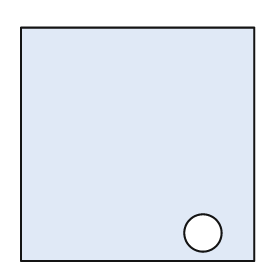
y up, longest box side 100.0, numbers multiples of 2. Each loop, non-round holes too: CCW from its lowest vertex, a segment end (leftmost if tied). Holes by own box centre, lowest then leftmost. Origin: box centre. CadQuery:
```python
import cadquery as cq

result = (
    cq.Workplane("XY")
    .moveTo(-50.0, -50.0)
    .lineTo(50.0, -50.0)
    .lineTo(50.0, 50.0)
    .lineTo(-50.0, 50.0)
    .close()
    .moveTo(28.0, -38.0)
    .circle(8.0)
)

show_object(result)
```